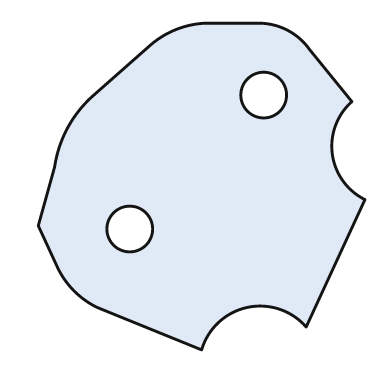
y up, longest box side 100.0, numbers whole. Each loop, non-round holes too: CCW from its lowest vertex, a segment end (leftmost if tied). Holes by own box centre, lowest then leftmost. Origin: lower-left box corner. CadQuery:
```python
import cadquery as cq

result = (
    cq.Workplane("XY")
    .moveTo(50.0, 0.0)
    .threePointArc((64.0, 13.0), (82.0, 7.0))
    .lineTo(100.0, 46.0)
    .threePointArc((90.0, 60.0), (96.0, 76.0))
    .lineTo(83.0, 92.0)
    .threePointArc((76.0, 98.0), (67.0, 100.0))
    .lineTo(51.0, 100.0)
    .threePointArc((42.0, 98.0), (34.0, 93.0))
    .lineTo(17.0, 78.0)
    .threePointArc((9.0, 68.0), (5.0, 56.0))
    .lineTo(0.0, 38.0)
    .lineTo(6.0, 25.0)
    .threePointArc((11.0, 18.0), (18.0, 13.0))
    .close()
    .moveTo(28.0, 37.0)
    .circle(7.0)
    .moveTo(69.0, 78.0)
    .circle(7.0)
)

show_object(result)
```